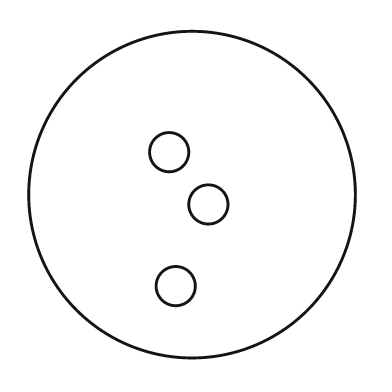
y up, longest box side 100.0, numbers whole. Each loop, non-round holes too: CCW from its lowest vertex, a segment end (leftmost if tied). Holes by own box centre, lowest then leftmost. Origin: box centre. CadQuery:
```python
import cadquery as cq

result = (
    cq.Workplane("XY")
    .moveTo(0.0, 0.0)
    .circle(50.0)
    .moveTo(-5.0, -28.0)
    .circle(6.0)
    .moveTo(5.0, -3.0)
    .circle(6.0)
    .moveTo(-7.0, 13.0)
    .circle(6.0)
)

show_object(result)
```